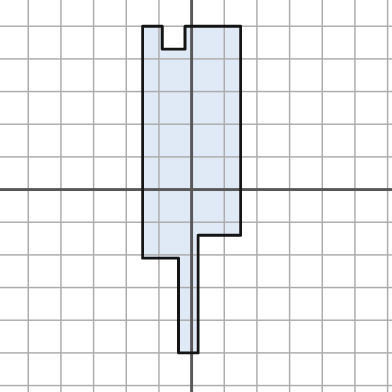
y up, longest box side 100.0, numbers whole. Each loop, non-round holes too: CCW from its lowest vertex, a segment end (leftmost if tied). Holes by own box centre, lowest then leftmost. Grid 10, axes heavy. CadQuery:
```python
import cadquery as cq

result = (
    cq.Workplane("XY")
    .moveTo(-4.0, -50.0)
    .lineTo(2.0, -50.0)
    .lineTo(2.0, -14.0)
    .lineTo(15.0, -14.0)
    .lineTo(15.0, 50.0)
    .lineTo(-2.0, 50.0)
    .lineTo(-2.0, 43.0)
    .lineTo(-9.0, 43.0)
    .lineTo(-9.0, 50.0)
    .lineTo(-15.0, 50.0)
    .lineTo(-15.0, -21.0)
    .lineTo(-4.0, -21.0)
    .close()
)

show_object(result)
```